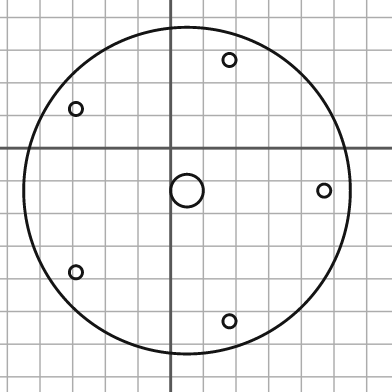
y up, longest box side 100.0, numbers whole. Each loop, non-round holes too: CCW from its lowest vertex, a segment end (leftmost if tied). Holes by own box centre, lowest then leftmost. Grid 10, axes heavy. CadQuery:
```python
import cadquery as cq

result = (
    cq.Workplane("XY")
    .moveTo(5.0, -13.0)
    .circle(50.0)
    .moveTo(18.0, -53.0)
    .circle(2.0)
    .moveTo(-29.0, -38.0)
    .circle(2.0)
    .moveTo(5.0, -13.0)
    .circle(5.0)
    .moveTo(47.0, -13.0)
    .circle(2.0)
    .moveTo(-29.0, 12.0)
    .circle(2.0)
    .moveTo(18.0, 27.0)
    .circle(2.0)
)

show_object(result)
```